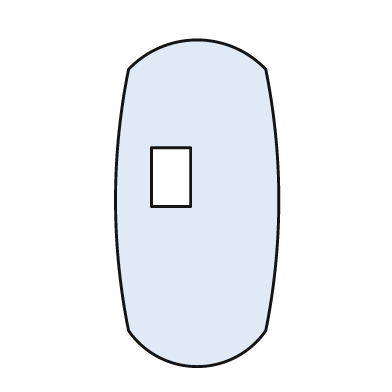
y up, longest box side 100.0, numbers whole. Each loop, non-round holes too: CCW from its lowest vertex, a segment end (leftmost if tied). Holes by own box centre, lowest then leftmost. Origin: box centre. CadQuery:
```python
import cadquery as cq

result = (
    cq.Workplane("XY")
    .moveTo(-21.0, -39.0)
    .threePointArc((0.0, -50.0), (21.0, -39.0))
    .threePointArc((25.0, 1.0), (21.0, 41.0))
    .threePointArc((0.0, 50.0), (-21.0, 41.0))
    .threePointArc((-25.0, 1.0), (-21.0, -39.0))
    .close()
    .moveTo(-14.0, -1.0)
    .lineTo(-2.0, -1.0)
    .lineTo(-2.0, 17.0)
    .lineTo(-14.0, 17.0)
    .close()
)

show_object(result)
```